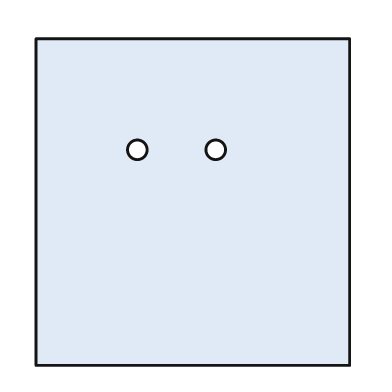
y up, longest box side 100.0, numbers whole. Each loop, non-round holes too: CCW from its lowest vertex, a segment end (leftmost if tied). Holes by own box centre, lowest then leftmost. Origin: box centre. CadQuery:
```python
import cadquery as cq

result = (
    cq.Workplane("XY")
    .moveTo(-48.0, -50.0)
    .lineTo(48.0, -50.0)
    .lineTo(48.0, 50.0)
    .lineTo(-48.0, 50.0)
    .close()
    .moveTo(-17.0, 16.0)
    .circle(3.0)
    .moveTo(7.0, 16.0)
    .circle(3.0)
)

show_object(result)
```